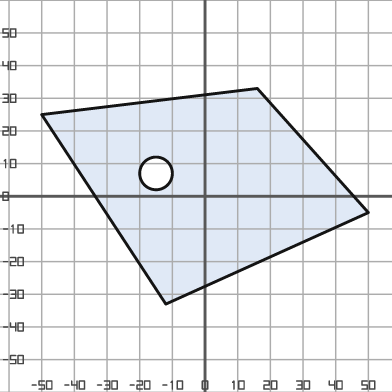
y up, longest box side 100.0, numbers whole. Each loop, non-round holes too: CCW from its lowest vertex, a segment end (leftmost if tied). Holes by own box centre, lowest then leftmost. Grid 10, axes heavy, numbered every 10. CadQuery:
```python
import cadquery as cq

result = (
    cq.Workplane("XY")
    .moveTo(-12.0, -33.0)
    .lineTo(50.0, -5.0)
    .lineTo(16.0, 33.0)
    .lineTo(-50.0, 25.0)
    .close()
    .moveTo(-15.0, 7.0)
    .circle(5.0)
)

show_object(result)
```